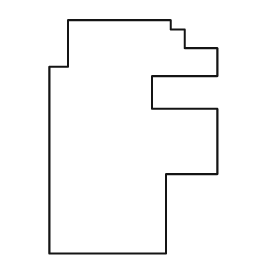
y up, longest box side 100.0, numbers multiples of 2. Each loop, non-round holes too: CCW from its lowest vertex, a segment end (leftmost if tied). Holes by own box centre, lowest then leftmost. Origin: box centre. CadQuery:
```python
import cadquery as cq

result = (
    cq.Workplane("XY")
    .moveTo(-36.0, -50.0)
    .lineTo(14.0, -50.0)
    .lineTo(14.0, -16.0)
    .lineTo(36.0, -16.0)
    .lineTo(36.0, 12.0)
    .lineTo(8.0, 12.0)
    .lineTo(8.0, 26.0)
    .lineTo(36.0, 26.0)
    .lineTo(36.0, 38.0)
    .lineTo(22.0, 38.0)
    .lineTo(22.0, 46.0)
    .lineTo(16.0, 46.0)
    .lineTo(16.0, 50.0)
    .lineTo(-28.0, 50.0)
    .lineTo(-28.0, 30.0)
    .lineTo(-36.0, 30.0)
    .close()
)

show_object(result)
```